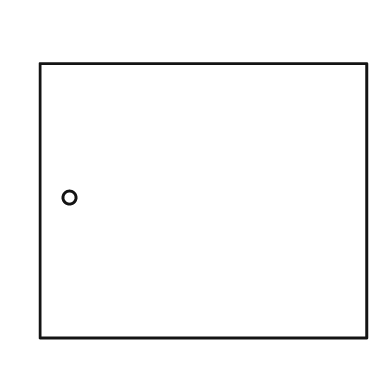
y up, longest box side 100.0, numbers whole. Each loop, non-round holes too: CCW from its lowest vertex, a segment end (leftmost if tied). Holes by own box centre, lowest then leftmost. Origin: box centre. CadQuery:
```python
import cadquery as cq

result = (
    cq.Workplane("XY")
    .moveTo(-50.0, -42.0)
    .lineTo(50.0, -42.0)
    .lineTo(50.0, 42.0)
    .lineTo(-50.0, 42.0)
    .close()
    .moveTo(-41.0, 1.0)
    .circle(2.0)
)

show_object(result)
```